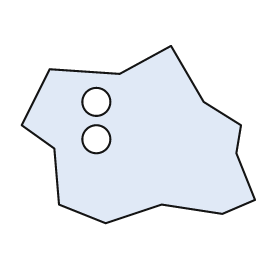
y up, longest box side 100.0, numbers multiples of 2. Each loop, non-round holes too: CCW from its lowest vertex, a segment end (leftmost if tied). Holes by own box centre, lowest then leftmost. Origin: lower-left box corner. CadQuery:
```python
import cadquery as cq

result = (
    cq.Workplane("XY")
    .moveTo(36.0, 0.0)
    .lineTo(60.0, 8.0)
    .lineTo(86.0, 4.0)
    .lineTo(100.0, 10.0)
    .lineTo(92.0, 30.0)
    .lineTo(94.0, 42.0)
    .lineTo(78.0, 52.0)
    .lineTo(64.0, 76.0)
    .lineTo(42.0, 64.0)
    .lineTo(12.0, 66.0)
    .lineTo(0.0, 42.0)
    .lineTo(14.0, 32.0)
    .lineTo(16.0, 8.0)
    .close()
    .moveTo(32.0, 36.0)
    .circle(6.0)
    .moveTo(32.0, 52.0)
    .circle(6.0)
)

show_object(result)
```